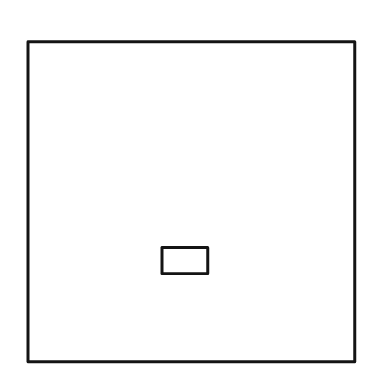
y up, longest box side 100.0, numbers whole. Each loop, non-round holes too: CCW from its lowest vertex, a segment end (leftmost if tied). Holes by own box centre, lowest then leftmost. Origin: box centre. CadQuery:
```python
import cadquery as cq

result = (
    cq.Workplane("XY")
    .moveTo(-50.0, -49.0)
    .lineTo(50.0, -49.0)
    .lineTo(50.0, 49.0)
    .lineTo(-50.0, 49.0)
    .close()
    .moveTo(-9.0, -22.0)
    .lineTo(5.0, -22.0)
    .lineTo(5.0, -14.0)
    .lineTo(-9.0, -14.0)
    .close()
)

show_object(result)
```